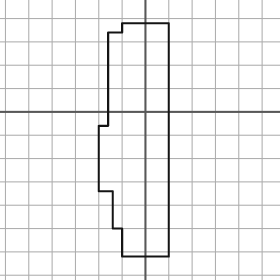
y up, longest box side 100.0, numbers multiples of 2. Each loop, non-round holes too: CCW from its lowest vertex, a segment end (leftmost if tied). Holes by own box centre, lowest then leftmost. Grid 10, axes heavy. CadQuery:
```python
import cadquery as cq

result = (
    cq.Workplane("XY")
    .moveTo(-10.0, -62.0)
    .lineTo(10.0, -62.0)
    .lineTo(10.0, 38.0)
    .lineTo(-10.0, 38.0)
    .lineTo(-10.0, 34.0)
    .lineTo(-16.0, 34.0)
    .lineTo(-16.0, -6.0)
    .lineTo(-20.0, -6.0)
    .lineTo(-20.0, -34.0)
    .lineTo(-14.0, -34.0)
    .lineTo(-14.0, -50.0)
    .lineTo(-10.0, -50.0)
    .close()
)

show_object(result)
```